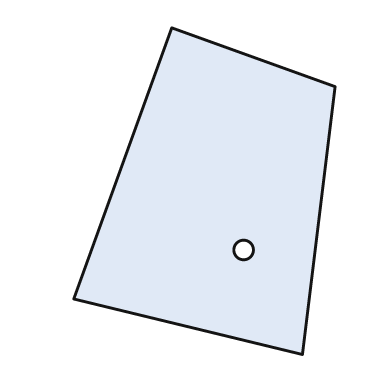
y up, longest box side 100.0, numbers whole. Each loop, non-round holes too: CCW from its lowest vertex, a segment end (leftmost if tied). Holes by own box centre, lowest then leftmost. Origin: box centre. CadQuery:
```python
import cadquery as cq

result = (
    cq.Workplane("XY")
    .moveTo(30.0, -50.0)
    .lineTo(40.0, 32.0)
    .lineTo(-10.0, 50.0)
    .lineTo(-40.0, -33.0)
    .close()
    .moveTo(12.0, -18.0)
    .circle(3.0)
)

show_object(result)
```